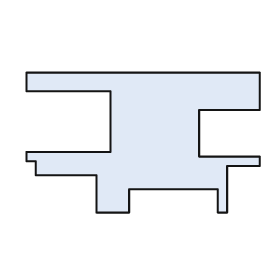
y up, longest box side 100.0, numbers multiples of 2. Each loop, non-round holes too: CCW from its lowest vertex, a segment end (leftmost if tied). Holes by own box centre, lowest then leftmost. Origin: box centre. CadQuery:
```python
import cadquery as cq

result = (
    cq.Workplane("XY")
    .moveTo(-20.0, -30.0)
    .lineTo(-6.0, -30.0)
    .lineTo(-6.0, -20.0)
    .lineTo(32.0, -20.0)
    .lineTo(32.0, -30.0)
    .lineTo(36.0, -30.0)
    .lineTo(36.0, -10.0)
    .lineTo(50.0, -10.0)
    .lineTo(50.0, -6.0)
    .lineTo(24.0, -6.0)
    .lineTo(24.0, 14.0)
    .lineTo(50.0, 14.0)
    .lineTo(50.0, 30.0)
    .lineTo(-50.0, 30.0)
    .lineTo(-50.0, 22.0)
    .lineTo(-14.0, 22.0)
    .lineTo(-14.0, -4.0)
    .lineTo(-50.0, -4.0)
    .lineTo(-50.0, -8.0)
    .lineTo(-46.0, -8.0)
    .lineTo(-46.0, -14.0)
    .lineTo(-20.0, -14.0)
    .close()
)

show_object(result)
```